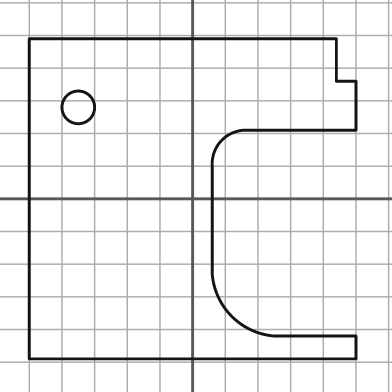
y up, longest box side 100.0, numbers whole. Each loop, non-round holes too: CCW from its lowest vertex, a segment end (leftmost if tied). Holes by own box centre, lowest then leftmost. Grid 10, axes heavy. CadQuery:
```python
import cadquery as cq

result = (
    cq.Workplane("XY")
    .moveTo(-50.0, -49.0)
    .lineTo(50.0, -49.0)
    .lineTo(50.0, -42.0)
    .lineTo(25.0, -42.0)
    .threePointArc((12.0, -36.0), (6.0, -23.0))
    .lineTo(6.0, 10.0)
    .threePointArc((9.0, 18.0), (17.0, 21.0))
    .lineTo(50.0, 21.0)
    .lineTo(50.0, 36.0)
    .lineTo(44.0, 36.0)
    .lineTo(44.0, 49.0)
    .lineTo(-50.0, 49.0)
    .close()
    .moveTo(-35.0, 28.0)
    .circle(5.0)
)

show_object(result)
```